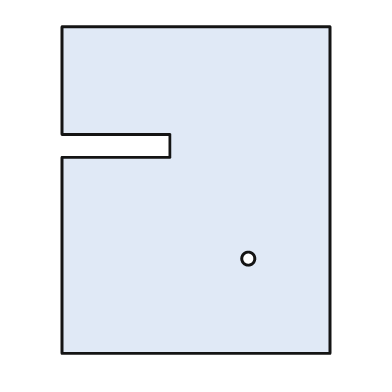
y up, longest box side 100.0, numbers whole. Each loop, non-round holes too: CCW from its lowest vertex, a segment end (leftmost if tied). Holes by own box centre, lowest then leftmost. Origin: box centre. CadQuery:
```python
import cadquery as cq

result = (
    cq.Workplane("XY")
    .moveTo(-41.0, -50.0)
    .lineTo(41.0, -50.0)
    .lineTo(41.0, 50.0)
    .lineTo(-41.0, 50.0)
    .lineTo(-41.0, 17.0)
    .lineTo(-8.0, 17.0)
    .lineTo(-8.0, 10.0)
    .lineTo(-41.0, 10.0)
    .close()
    .moveTo(16.0, -21.0)
    .circle(2.0)
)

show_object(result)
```